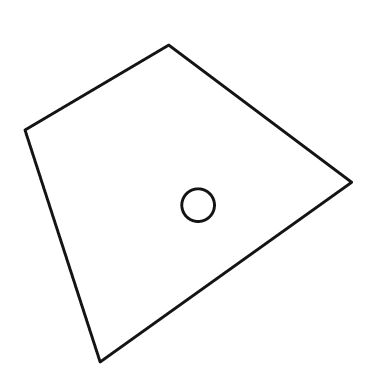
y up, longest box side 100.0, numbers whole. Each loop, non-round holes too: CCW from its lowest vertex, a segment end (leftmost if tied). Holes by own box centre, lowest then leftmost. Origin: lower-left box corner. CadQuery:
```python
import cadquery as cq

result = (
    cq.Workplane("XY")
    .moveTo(23.0, 0.0)
    .lineTo(100.0, 55.0)
    .lineTo(44.0, 97.0)
    .lineTo(0.0, 71.0)
    .close()
    .moveTo(53.0, 48.0)
    .circle(5.0)
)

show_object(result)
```